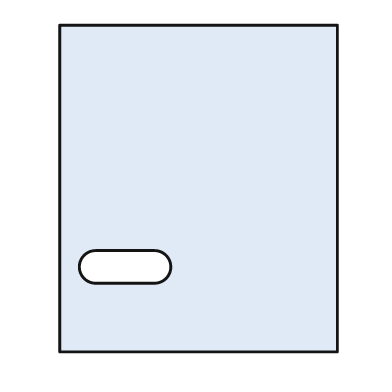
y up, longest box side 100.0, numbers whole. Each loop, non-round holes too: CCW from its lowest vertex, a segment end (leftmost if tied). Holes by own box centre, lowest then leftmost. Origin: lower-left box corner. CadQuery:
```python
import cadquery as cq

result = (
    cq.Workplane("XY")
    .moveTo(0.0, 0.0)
    .lineTo(85.0, 0.0)
    .lineTo(85.0, 100.0)
    .lineTo(0.0, 100.0)
    .close()
    .moveTo(11.0, 21.0)
    .lineTo(29.0, 21.0)
    .threePointArc((34.0, 26.0), (29.0, 31.0))
    .lineTo(11.0, 31.0)
    .threePointArc((6.0, 26.0), (11.0, 21.0))
    .close()
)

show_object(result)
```